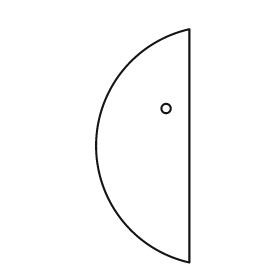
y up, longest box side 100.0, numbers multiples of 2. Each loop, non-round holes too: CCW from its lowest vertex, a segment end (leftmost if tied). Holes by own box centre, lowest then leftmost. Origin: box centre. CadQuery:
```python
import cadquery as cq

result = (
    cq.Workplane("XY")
    .moveTo(20.0, -50.0)
    .lineTo(20.0, 50.0)
    .threePointArc((-20.0, 0.0), (20.0, -50.0))
    .close()
    .moveTo(10.0, 16.0)
    .circle(2.0)
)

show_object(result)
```